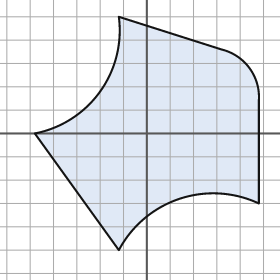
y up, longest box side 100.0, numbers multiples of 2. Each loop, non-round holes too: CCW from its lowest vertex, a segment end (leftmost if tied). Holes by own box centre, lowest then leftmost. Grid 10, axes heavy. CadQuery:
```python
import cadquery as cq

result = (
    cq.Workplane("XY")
    .moveTo(-12.0, -50.0)
    .threePointArc((14.0, -28.0), (48.0, -30.0))
    .lineTo(48.0, 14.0)
    .threePointArc((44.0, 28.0), (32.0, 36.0))
    .lineTo(-12.0, 50.0)
    .threePointArc((-20.0, 18.0), (-48.0, 0.0))
    .close()
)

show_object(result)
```